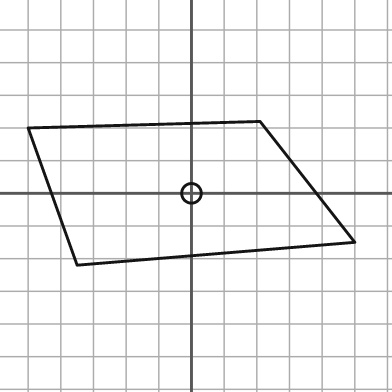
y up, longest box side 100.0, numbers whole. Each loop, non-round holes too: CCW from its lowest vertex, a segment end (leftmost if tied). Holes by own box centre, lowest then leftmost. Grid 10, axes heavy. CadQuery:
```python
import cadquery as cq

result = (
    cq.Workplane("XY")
    .moveTo(-35.0, -22.0)
    .lineTo(50.0, -15.0)
    .lineTo(21.0, 22.0)
    .lineTo(-50.0, 20.0)
    .close()
    .moveTo(0.0, 0.0)
    .circle(3.0)
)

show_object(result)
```